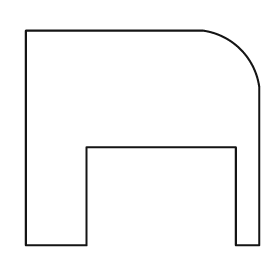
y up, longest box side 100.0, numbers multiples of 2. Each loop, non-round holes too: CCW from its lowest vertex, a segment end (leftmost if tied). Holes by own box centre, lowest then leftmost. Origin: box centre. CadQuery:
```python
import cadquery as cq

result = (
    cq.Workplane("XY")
    .moveTo(-50.0, -46.0)
    .lineTo(-24.0, -46.0)
    .lineTo(-24.0, -4.0)
    .lineTo(40.0, -4.0)
    .lineTo(40.0, -46.0)
    .lineTo(50.0, -46.0)
    .lineTo(50.0, 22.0)
    .threePointArc((42.0, 38.0), (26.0, 46.0))
    .lineTo(-50.0, 46.0)
    .close()
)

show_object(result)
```